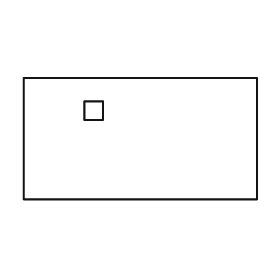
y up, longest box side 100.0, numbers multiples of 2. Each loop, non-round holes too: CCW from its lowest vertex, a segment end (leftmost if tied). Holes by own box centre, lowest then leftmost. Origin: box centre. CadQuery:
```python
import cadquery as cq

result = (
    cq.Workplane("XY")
    .moveTo(-50.0, -26.0)
    .lineTo(50.0, -26.0)
    .lineTo(50.0, 26.0)
    .lineTo(-50.0, 26.0)
    .close()
    .moveTo(-24.0, 8.0)
    .lineTo(-16.0, 8.0)
    .lineTo(-16.0, 16.0)
    .lineTo(-24.0, 16.0)
    .close()
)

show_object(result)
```